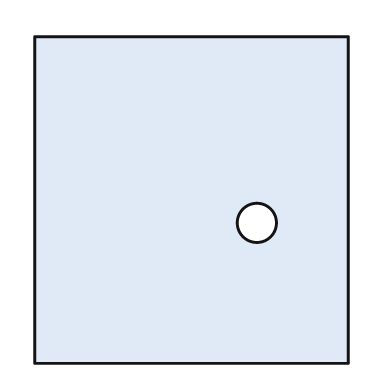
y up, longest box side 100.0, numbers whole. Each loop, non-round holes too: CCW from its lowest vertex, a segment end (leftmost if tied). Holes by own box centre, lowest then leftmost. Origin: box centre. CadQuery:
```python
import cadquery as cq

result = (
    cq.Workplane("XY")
    .moveTo(-48.0, -50.0)
    .lineTo(48.0, -50.0)
    .lineTo(48.0, 50.0)
    .lineTo(-48.0, 50.0)
    .close()
    .moveTo(20.0, -7.0)
    .circle(6.0)
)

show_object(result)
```